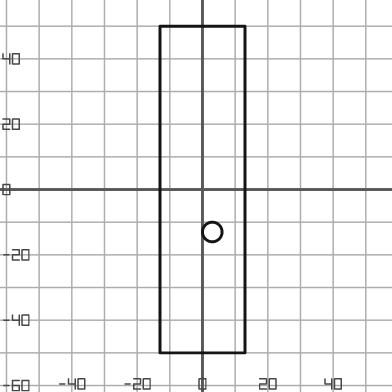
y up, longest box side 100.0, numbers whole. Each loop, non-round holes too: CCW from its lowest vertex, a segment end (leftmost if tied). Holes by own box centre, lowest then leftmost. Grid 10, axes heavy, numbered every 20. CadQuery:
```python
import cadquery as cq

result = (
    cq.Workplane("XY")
    .moveTo(-13.0, -50.0)
    .lineTo(13.0, -50.0)
    .lineTo(13.0, 50.0)
    .lineTo(-13.0, 50.0)
    .close()
    .moveTo(3.0, -13.0)
    .circle(3.0)
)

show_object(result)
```